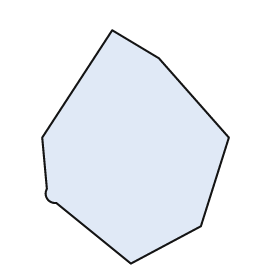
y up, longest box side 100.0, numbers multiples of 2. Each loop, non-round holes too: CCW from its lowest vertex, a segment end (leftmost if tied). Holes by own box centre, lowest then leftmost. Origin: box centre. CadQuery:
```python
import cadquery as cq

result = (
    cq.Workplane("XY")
    .moveTo(-2.0, -50.0)
    .lineTo(28.0, -34.0)
    .lineTo(40.0, 4.0)
    .lineTo(10.0, 38.0)
    .lineTo(-10.0, 50.0)
    .lineTo(-40.0, 4.0)
    .lineTo(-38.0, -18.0)
    .threePointArc((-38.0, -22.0), (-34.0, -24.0))
    .close()
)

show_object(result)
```